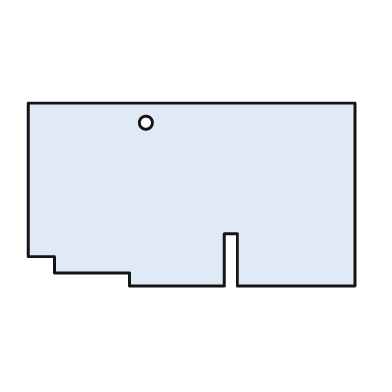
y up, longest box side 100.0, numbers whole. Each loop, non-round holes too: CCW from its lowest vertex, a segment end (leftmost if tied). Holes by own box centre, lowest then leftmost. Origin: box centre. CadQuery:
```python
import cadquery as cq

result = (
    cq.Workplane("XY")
    .moveTo(-19.0, -28.0)
    .lineTo(10.0, -28.0)
    .lineTo(10.0, -12.0)
    .lineTo(14.0, -12.0)
    .lineTo(14.0, -28.0)
    .lineTo(50.0, -28.0)
    .lineTo(50.0, 28.0)
    .lineTo(-50.0, 28.0)
    .lineTo(-50.0, -19.0)
    .lineTo(-42.0, -19.0)
    .lineTo(-42.0, -24.0)
    .lineTo(-19.0, -24.0)
    .close()
    .moveTo(-14.0, 22.0)
    .circle(2.0)
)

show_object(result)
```